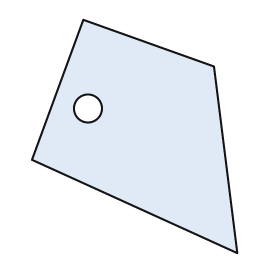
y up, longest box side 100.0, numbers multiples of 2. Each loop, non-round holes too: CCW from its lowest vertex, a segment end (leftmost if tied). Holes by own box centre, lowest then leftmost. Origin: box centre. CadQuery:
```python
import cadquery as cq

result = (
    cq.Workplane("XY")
    .moveTo(44.0, -50.0)
    .lineTo(34.0, 30.0)
    .lineTo(-22.0, 50.0)
    .lineTo(-44.0, -10.0)
    .close()
    .moveTo(-20.0, 12.0)
    .circle(6.0)
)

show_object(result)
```